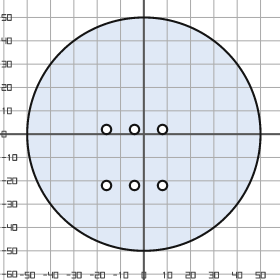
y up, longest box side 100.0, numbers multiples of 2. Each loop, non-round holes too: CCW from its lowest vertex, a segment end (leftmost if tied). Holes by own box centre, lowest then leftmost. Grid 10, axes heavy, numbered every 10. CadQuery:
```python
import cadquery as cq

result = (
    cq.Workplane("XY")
    .moveTo(0.0, 0.0)
    .circle(50.0)
    .moveTo(-16.0, -22.0)
    .circle(2.0)
    .moveTo(-4.0, -22.0)
    .circle(2.0)
    .moveTo(8.0, -22.0)
    .circle(2.0)
    .moveTo(-16.0, 2.0)
    .circle(2.0)
    .moveTo(-4.0, 2.0)
    .circle(2.0)
    .moveTo(8.0, 2.0)
    .circle(2.0)
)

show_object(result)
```